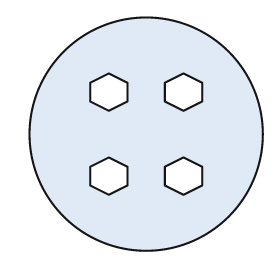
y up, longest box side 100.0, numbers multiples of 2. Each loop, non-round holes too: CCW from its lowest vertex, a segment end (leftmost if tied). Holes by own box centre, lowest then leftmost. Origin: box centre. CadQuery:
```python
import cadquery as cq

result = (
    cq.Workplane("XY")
    .moveTo(0.0, 0.0)
    .circle(50.0)
    .moveTo(-16.0, -26.0)
    .lineTo(-8.0, -22.0)
    .lineTo(-8.0, -14.0)
    .lineTo(-16.0, -10.0)
    .lineTo(-24.0, -14.0)
    .lineTo(-24.0, -22.0)
    .close()
    .moveTo(16.0, -26.0)
    .lineTo(24.0, -22.0)
    .lineTo(24.0, -14.0)
    .lineTo(16.0, -10.0)
    .lineTo(8.0, -14.0)
    .lineTo(8.0, -22.0)
    .close()
    .moveTo(-16.0, 10.0)
    .lineTo(-8.0, 14.0)
    .lineTo(-8.0, 22.0)
    .lineTo(-16.0, 26.0)
    .lineTo(-24.0, 22.0)
    .lineTo(-24.0, 14.0)
    .close()
    .moveTo(16.0, 10.0)
    .lineTo(24.0, 14.0)
    .lineTo(24.0, 22.0)
    .lineTo(16.0, 26.0)
    .lineTo(8.0, 22.0)
    .lineTo(8.0, 14.0)
    .close()
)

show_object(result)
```